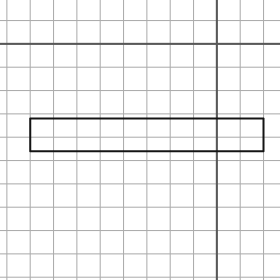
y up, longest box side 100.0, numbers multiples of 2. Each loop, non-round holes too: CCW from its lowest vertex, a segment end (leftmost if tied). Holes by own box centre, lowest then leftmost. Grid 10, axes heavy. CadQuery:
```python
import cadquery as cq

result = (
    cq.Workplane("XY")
    .moveTo(-80.0, -46.0)
    .lineTo(20.0, -46.0)
    .lineTo(20.0, -32.0)
    .lineTo(-80.0, -32.0)
    .close()
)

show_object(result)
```